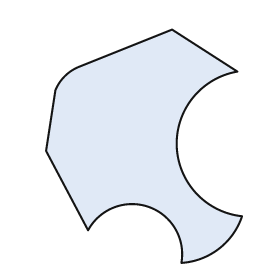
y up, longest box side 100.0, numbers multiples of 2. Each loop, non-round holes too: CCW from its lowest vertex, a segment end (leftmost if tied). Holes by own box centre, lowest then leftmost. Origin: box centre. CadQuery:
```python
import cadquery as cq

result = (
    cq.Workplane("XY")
    .moveTo(16.0, -50.0)
    .threePointArc((32.0, -44.0), (42.0, -30.0))
    .threePointArc((14.0, 0.0), (40.0, 32.0))
    .lineTo(12.0, 50.0)
    .lineTo(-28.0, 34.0)
    .threePointArc((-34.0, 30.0), (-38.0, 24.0))
    .lineTo(-42.0, -2.0)
    .lineTo(-24.0, -36.0)
    .threePointArc((2.0, -26.0), (16.0, -50.0))
    .close()
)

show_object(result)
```